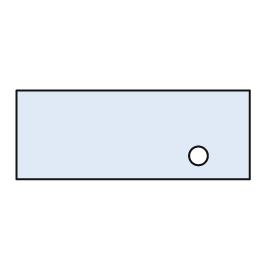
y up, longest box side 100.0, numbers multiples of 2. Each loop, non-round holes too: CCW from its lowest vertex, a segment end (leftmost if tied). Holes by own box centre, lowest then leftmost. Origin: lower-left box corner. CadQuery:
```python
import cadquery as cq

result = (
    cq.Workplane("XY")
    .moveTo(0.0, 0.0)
    .lineTo(100.0, 0.0)
    .lineTo(100.0, 38.0)
    .lineTo(0.0, 38.0)
    .close()
    .moveTo(78.0, 10.0)
    .circle(4.0)
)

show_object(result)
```